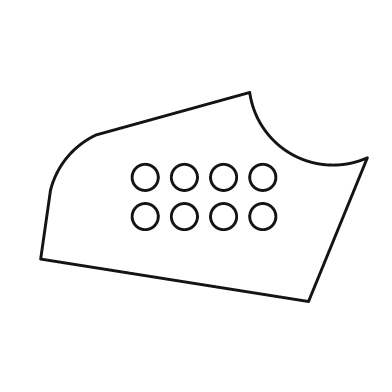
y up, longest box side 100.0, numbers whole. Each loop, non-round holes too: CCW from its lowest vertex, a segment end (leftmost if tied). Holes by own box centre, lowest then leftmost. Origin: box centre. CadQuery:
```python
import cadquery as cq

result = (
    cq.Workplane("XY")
    .moveTo(32.0, -32.0)
    .lineTo(50.0, 12.0)
    .threePointArc((27.0, 13.0), (14.0, 32.0))
    .lineTo(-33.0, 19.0)
    .threePointArc((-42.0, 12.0), (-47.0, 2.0))
    .lineTo(-50.0, -19.0)
    .close()
    .moveTo(-18.0, -6.0)
    .circle(4.0)
    .moveTo(-6.0, -6.0)
    .circle(4.0)
    .moveTo(6.0, -6.0)
    .circle(4.0)
    .moveTo(18.0, -6.0)
    .circle(4.0)
    .moveTo(-18.0, 6.0)
    .circle(4.0)
    .moveTo(-6.0, 6.0)
    .circle(4.0)
    .moveTo(6.0, 6.0)
    .circle(4.0)
    .moveTo(18.0, 6.0)
    .circle(4.0)
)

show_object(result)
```